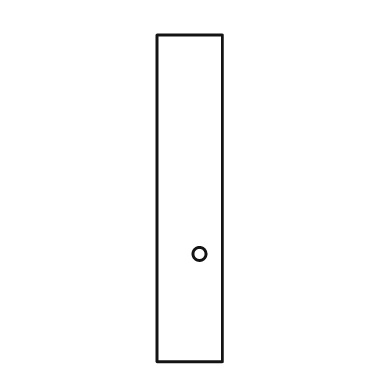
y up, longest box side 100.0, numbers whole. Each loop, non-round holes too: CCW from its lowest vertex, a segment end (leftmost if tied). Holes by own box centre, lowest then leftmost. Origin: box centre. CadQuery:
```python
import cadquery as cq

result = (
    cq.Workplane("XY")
    .moveTo(-10.0, -50.0)
    .lineTo(10.0, -50.0)
    .lineTo(10.0, 50.0)
    .lineTo(-10.0, 50.0)
    .close()
    .moveTo(3.0, -17.0)
    .circle(2.0)
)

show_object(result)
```